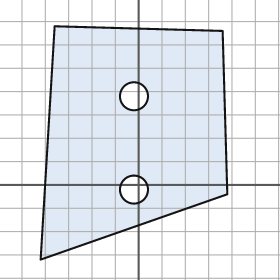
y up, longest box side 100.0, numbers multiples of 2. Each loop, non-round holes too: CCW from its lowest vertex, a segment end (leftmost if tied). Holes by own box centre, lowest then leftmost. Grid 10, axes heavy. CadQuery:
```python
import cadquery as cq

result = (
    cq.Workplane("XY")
    .moveTo(-42.0, -32.0)
    .lineTo(38.0, -4.0)
    .lineTo(36.0, 66.0)
    .lineTo(-36.0, 68.0)
    .close()
    .moveTo(-2.0, -2.0)
    .circle(6.0)
    .moveTo(-2.0, 38.0)
    .circle(6.0)
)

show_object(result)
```